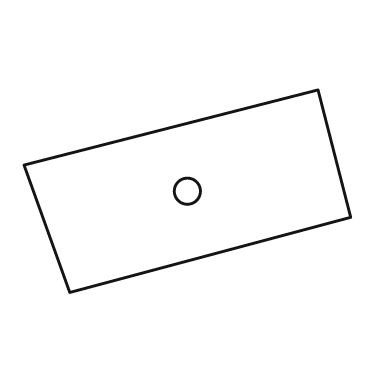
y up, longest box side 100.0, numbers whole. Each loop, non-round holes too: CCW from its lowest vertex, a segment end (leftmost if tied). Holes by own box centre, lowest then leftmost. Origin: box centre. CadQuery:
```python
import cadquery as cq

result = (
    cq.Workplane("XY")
    .moveTo(-36.0, -31.0)
    .lineTo(50.0, -8.0)
    .lineTo(40.0, 31.0)
    .lineTo(-50.0, 8.0)
    .close()
    .moveTo(0.0, 0.0)
    .circle(4.0)
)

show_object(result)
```